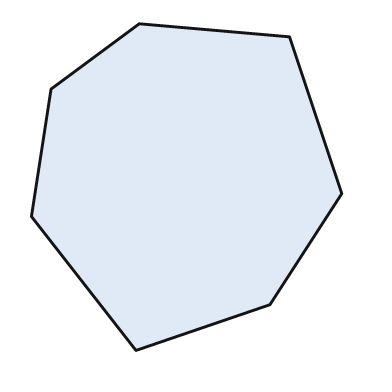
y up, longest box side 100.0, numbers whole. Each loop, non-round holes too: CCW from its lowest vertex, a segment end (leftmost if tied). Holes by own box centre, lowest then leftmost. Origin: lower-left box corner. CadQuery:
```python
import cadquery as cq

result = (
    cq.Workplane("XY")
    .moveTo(32.0, 0.0)
    .lineTo(73.0, 14.0)
    .lineTo(95.0, 48.0)
    .lineTo(79.0, 96.0)
    .lineTo(33.0, 100.0)
    .lineTo(6.0, 80.0)
    .lineTo(0.0, 41.0)
    .close()
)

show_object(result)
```